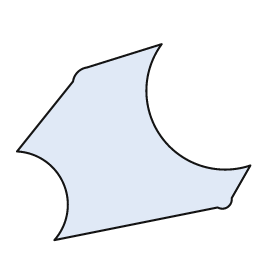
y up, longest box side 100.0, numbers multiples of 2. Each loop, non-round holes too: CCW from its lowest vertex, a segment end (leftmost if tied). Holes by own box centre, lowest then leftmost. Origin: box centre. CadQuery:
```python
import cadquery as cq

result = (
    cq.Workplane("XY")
    .moveTo(-34.0, -42.0)
    .lineTo(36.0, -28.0)
    .threePointArc((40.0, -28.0), (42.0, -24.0))
    .lineTo(50.0, -10.0)
    .threePointArc((12.0, 2.0), (12.0, 42.0))
    .lineTo(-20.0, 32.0)
    .threePointArc((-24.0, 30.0), (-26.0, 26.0))
    .lineTo(-50.0, -4.0)
    .threePointArc((-30.0, -18.0), (-34.0, -42.0))
    .close()
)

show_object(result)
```